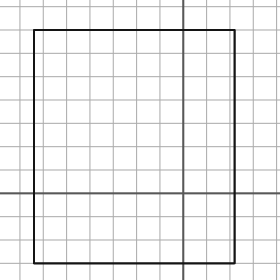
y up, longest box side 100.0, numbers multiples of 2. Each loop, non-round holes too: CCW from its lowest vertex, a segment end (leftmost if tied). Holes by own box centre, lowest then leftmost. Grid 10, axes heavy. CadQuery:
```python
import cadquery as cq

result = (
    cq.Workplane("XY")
    .moveTo(-64.0, -30.0)
    .lineTo(22.0, -30.0)
    .lineTo(22.0, 70.0)
    .lineTo(-64.0, 70.0)
    .close()
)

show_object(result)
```